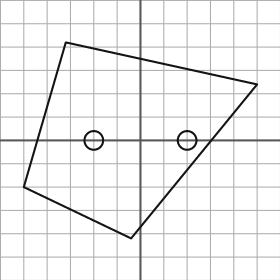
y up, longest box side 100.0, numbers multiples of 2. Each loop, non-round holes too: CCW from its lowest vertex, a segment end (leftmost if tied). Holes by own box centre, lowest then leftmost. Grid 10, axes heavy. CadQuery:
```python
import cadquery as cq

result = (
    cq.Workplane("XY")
    .moveTo(-4.0, -42.0)
    .lineTo(50.0, 24.0)
    .lineTo(-32.0, 42.0)
    .lineTo(-50.0, -20.0)
    .close()
    .moveTo(-20.0, 0.0)
    .circle(4.0)
    .moveTo(20.0, 0.0)
    .circle(4.0)
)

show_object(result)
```